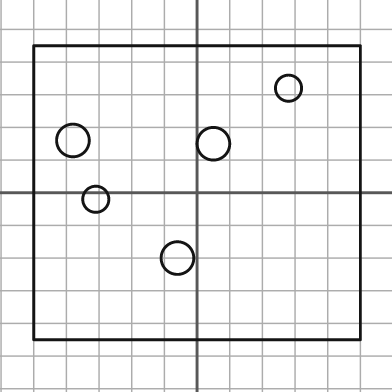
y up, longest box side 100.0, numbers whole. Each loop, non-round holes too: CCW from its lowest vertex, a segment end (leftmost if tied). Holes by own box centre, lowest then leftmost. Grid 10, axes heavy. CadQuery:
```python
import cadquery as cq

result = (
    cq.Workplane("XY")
    .moveTo(-50.0, -45.0)
    .lineTo(50.0, -45.0)
    .lineTo(50.0, 45.0)
    .lineTo(-50.0, 45.0)
    .close()
    .moveTo(-6.0, -20.0)
    .circle(5.0)
    .moveTo(-31.0, -2.0)
    .circle(4.0)
    .moveTo(5.0, 15.0)
    .circle(5.0)
    .moveTo(-38.0, 16.0)
    .circle(5.0)
    .moveTo(28.0, 32.0)
    .circle(4.0)
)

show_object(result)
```